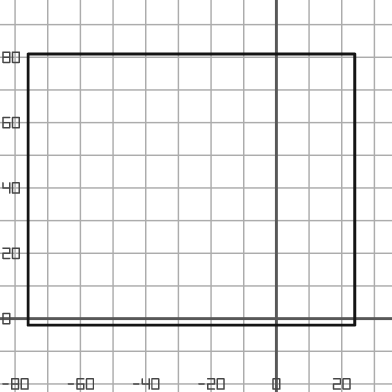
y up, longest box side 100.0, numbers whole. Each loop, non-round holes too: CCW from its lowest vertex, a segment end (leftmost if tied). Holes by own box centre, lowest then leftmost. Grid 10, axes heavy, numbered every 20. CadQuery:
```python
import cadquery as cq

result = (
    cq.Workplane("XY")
    .moveTo(-76.0, -2.0)
    .lineTo(24.0, -2.0)
    .lineTo(24.0, 81.0)
    .lineTo(-76.0, 81.0)
    .close()
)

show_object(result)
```